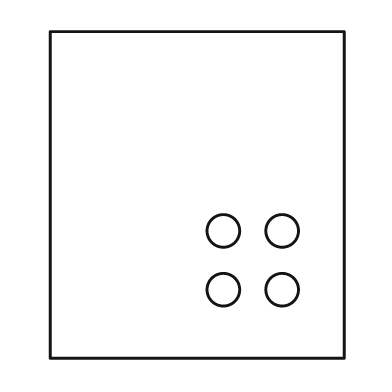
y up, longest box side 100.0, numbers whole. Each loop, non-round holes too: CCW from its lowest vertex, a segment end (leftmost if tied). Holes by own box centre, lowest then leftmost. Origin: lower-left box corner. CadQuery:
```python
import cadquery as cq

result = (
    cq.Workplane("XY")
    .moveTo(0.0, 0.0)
    .lineTo(90.0, 0.0)
    .lineTo(90.0, 100.0)
    .lineTo(0.0, 100.0)
    .close()
    .moveTo(53.0, 21.0)
    .circle(5.0)
    .moveTo(71.0, 21.0)
    .circle(5.0)
    .moveTo(53.0, 39.0)
    .circle(5.0)
    .moveTo(71.0, 39.0)
    .circle(5.0)
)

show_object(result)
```